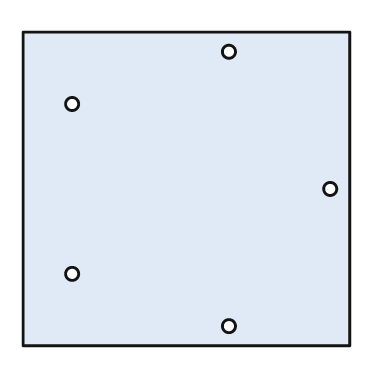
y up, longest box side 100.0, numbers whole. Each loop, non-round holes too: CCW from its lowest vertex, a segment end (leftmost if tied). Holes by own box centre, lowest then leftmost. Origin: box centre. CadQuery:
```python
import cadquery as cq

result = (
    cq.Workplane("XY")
    .moveTo(-50.0, -48.0)
    .lineTo(50.0, -48.0)
    .lineTo(50.0, 48.0)
    .lineTo(-50.0, 48.0)
    .close()
    .moveTo(13.0, -42.0)
    .circle(2.0)
    .moveTo(-35.0, -26.0)
    .circle(2.0)
    .moveTo(44.0, 0.0)
    .circle(2.0)
    .moveTo(-35.0, 26.0)
    .circle(2.0)
    .moveTo(13.0, 42.0)
    .circle(2.0)
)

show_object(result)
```